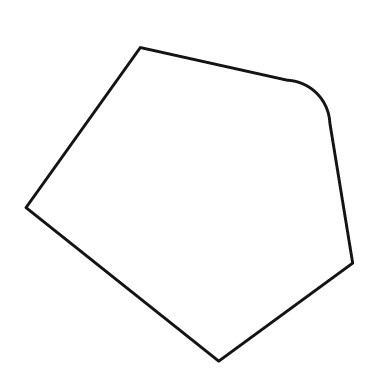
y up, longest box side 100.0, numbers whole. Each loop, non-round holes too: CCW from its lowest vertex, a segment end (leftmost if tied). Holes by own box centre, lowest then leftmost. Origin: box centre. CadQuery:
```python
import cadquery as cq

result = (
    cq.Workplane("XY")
    .moveTo(9.0, -48.0)
    .lineTo(50.0, -18.0)
    .lineTo(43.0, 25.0)
    .threePointArc((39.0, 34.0), (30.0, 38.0))
    .lineTo(-15.0, 48.0)
    .lineTo(-50.0, -1.0)
    .close()
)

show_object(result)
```